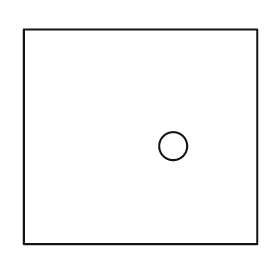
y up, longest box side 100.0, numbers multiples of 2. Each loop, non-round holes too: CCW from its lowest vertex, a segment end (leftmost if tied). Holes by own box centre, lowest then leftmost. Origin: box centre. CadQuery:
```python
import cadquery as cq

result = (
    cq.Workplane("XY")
    .moveTo(-50.0, -46.0)
    .lineTo(50.0, -46.0)
    .lineTo(50.0, 46.0)
    .lineTo(-50.0, 46.0)
    .close()
    .moveTo(14.0, -4.0)
    .circle(6.0)
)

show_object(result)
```